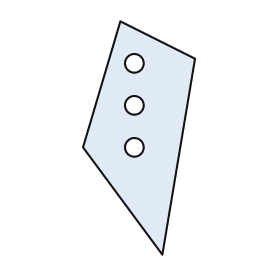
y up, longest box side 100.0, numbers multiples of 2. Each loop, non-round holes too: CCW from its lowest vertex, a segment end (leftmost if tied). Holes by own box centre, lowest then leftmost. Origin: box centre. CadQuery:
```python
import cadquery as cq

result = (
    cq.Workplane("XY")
    .moveTo(10.0, -50.0)
    .lineTo(24.0, 34.0)
    .lineTo(-8.0, 50.0)
    .lineTo(-24.0, -4.0)
    .close()
    .moveTo(-2.0, -4.0)
    .circle(4.0)
    .moveTo(-2.0, 14.0)
    .circle(4.0)
    .moveTo(-2.0, 32.0)
    .circle(4.0)
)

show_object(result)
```